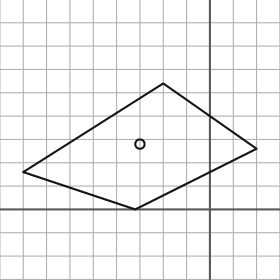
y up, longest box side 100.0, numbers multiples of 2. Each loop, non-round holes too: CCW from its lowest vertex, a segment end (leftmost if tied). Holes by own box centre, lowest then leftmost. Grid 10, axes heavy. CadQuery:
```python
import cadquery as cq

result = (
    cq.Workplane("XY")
    .moveTo(-32.0, 0.0)
    .lineTo(20.0, 26.0)
    .lineTo(-20.0, 54.0)
    .lineTo(-80.0, 16.0)
    .close()
    .moveTo(-30.0, 28.0)
    .circle(2.0)
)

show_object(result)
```